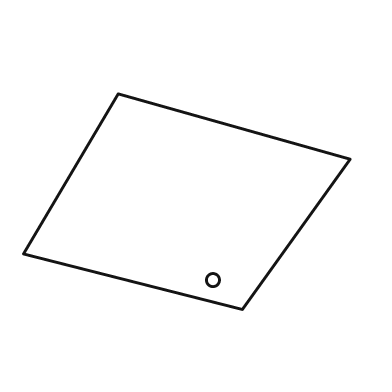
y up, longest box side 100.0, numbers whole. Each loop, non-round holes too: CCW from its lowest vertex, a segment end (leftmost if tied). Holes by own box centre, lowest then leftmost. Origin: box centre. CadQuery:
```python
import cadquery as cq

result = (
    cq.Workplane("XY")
    .moveTo(17.0, -33.0)
    .lineTo(50.0, 13.0)
    .lineTo(-21.0, 33.0)
    .lineTo(-50.0, -16.0)
    .close()
    .moveTo(8.0, -24.0)
    .circle(2.0)
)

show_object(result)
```